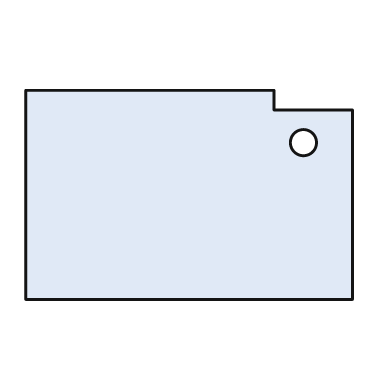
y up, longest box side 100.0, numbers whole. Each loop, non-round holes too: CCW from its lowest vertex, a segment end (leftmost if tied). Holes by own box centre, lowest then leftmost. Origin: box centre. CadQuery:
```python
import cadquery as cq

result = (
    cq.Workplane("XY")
    .moveTo(-50.0, -32.0)
    .lineTo(50.0, -32.0)
    .lineTo(50.0, 26.0)
    .lineTo(26.0, 26.0)
    .lineTo(26.0, 32.0)
    .lineTo(-50.0, 32.0)
    .close()
    .moveTo(35.0, 16.0)
    .circle(4.0)
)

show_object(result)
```